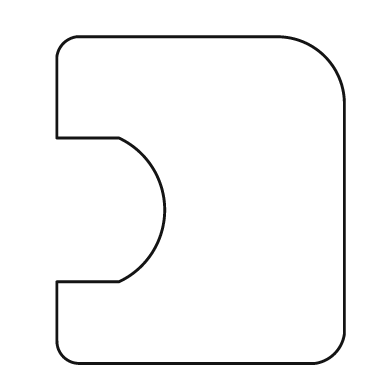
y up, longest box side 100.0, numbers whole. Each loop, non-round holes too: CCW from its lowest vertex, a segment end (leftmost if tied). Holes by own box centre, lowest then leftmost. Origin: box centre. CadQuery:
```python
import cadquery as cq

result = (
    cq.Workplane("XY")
    .moveTo(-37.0, -50.0)
    .lineTo(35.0, -50.0)
    .threePointArc((41.0, -47.0), (44.0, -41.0))
    .lineTo(44.0, 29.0)
    .threePointArc((38.0, 44.0), (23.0, 50.0))
    .lineTo(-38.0, 50.0)
    .threePointArc((-42.0, 48.0), (-44.0, 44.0))
    .lineTo(-44.0, 19.0)
    .lineTo(-25.0, 19.0)
    .threePointArc((-11.0, -3.0), (-25.0, -25.0))
    .lineTo(-44.0, -25.0)
    .lineTo(-44.0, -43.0)
    .threePointArc((-42.0, -48.0), (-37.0, -50.0))
    .close()
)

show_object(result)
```